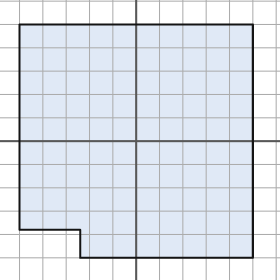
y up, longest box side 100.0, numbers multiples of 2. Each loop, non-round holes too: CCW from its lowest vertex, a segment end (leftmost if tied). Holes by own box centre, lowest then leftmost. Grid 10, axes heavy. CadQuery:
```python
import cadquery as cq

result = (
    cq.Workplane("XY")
    .moveTo(-24.0, -50.0)
    .lineTo(50.0, -50.0)
    .lineTo(50.0, 50.0)
    .lineTo(-50.0, 50.0)
    .lineTo(-50.0, -38.0)
    .lineTo(-24.0, -38.0)
    .close()
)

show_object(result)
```